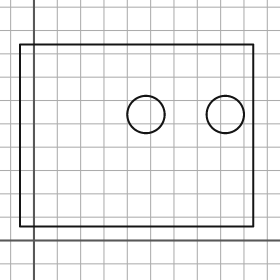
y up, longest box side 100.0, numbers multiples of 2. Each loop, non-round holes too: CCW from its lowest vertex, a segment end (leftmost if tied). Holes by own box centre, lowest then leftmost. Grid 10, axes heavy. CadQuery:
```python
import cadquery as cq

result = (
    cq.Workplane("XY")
    .moveTo(-6.0, 6.0)
    .lineTo(94.0, 6.0)
    .lineTo(94.0, 84.0)
    .lineTo(-6.0, 84.0)
    .close()
    .moveTo(48.0, 54.0)
    .circle(8.0)
    .moveTo(82.0, 54.0)
    .circle(8.0)
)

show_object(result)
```